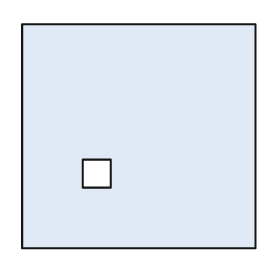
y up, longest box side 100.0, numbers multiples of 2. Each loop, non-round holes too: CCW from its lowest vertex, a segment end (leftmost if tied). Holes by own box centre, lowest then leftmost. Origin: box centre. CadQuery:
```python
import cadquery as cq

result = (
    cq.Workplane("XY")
    .moveTo(-50.0, -48.0)
    .lineTo(50.0, -48.0)
    .lineTo(50.0, 48.0)
    .lineTo(-50.0, 48.0)
    .close()
    .moveTo(-24.0, -22.0)
    .lineTo(-12.0, -22.0)
    .lineTo(-12.0, -10.0)
    .lineTo(-24.0, -10.0)
    .close()
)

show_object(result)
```